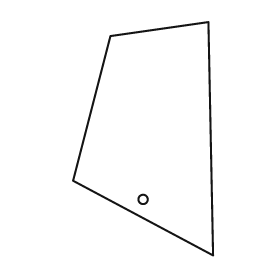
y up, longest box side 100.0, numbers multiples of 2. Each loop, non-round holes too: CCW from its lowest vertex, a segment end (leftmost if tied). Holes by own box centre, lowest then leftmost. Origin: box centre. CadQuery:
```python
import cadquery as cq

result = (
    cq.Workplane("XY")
    .moveTo(30.0, -50.0)
    .lineTo(28.0, 50.0)
    .lineTo(-14.0, 44.0)
    .lineTo(-30.0, -18.0)
    .close()
    .moveTo(0.0, -26.0)
    .circle(2.0)
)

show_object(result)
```